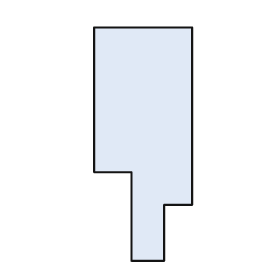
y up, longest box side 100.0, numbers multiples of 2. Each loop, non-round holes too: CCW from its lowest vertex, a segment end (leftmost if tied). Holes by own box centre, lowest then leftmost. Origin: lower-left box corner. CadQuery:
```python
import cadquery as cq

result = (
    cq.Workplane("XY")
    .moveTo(16.0, 0.0)
    .lineTo(30.0, 0.0)
    .lineTo(30.0, 24.0)
    .lineTo(42.0, 24.0)
    .lineTo(42.0, 100.0)
    .lineTo(0.0, 100.0)
    .lineTo(0.0, 38.0)
    .lineTo(16.0, 38.0)
    .close()
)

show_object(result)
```